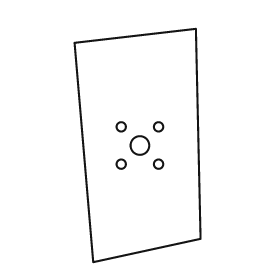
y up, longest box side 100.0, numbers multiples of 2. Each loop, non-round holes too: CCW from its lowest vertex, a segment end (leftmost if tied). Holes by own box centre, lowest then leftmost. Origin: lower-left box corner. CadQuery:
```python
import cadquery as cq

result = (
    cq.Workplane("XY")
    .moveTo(8.0, 0.0)
    .lineTo(54.0, 10.0)
    .lineTo(52.0, 100.0)
    .lineTo(0.0, 94.0)
    .close()
    .moveTo(20.0, 42.0)
    .circle(2.0)
    .moveTo(36.0, 42.0)
    .circle(2.0)
    .moveTo(28.0, 50.0)
    .circle(4.0)
    .moveTo(20.0, 58.0)
    .circle(2.0)
    .moveTo(36.0, 58.0)
    .circle(2.0)
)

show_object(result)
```